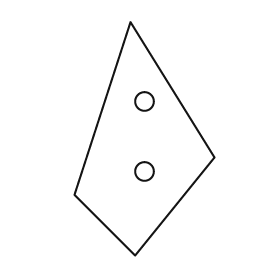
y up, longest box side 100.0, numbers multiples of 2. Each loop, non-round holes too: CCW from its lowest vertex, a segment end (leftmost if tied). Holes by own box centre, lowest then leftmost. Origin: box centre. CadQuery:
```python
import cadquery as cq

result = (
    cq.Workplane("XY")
    .moveTo(-4.0, -50.0)
    .lineTo(30.0, -8.0)
    .lineTo(-6.0, 50.0)
    .lineTo(-30.0, -24.0)
    .close()
    .moveTo(0.0, -14.0)
    .circle(4.0)
    .moveTo(0.0, 16.0)
    .circle(4.0)
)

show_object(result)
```